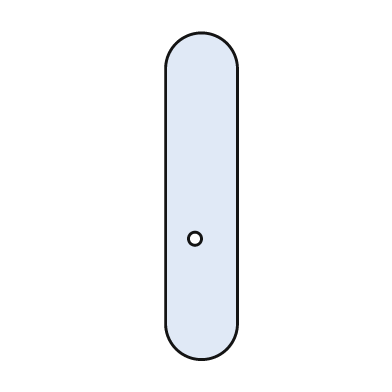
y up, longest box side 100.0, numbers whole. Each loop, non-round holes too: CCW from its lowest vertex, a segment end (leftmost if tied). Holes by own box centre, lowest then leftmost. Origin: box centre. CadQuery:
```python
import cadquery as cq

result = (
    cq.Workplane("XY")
    .moveTo(-11.0, -39.0)
    .threePointArc((0.0, -50.0), (11.0, -39.0))
    .lineTo(11.0, 39.0)
    .threePointArc((0.0, 50.0), (-11.0, 39.0))
    .close()
    .moveTo(-2.0, -13.0)
    .circle(2.0)
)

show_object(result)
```